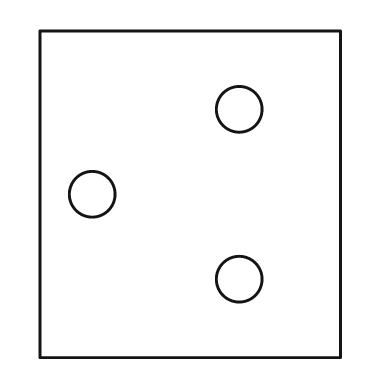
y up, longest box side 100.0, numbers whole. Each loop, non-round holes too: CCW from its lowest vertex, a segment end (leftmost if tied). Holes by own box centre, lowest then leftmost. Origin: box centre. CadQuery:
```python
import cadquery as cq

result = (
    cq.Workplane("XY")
    .moveTo(-46.0, -50.0)
    .lineTo(46.0, -50.0)
    .lineTo(46.0, 50.0)
    .lineTo(-46.0, 50.0)
    .close()
    .moveTo(15.0, -26.0)
    .circle(7.0)
    .moveTo(-30.0, 0.0)
    .circle(7.0)
    .moveTo(15.0, 26.0)
    .circle(7.0)
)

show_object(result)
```